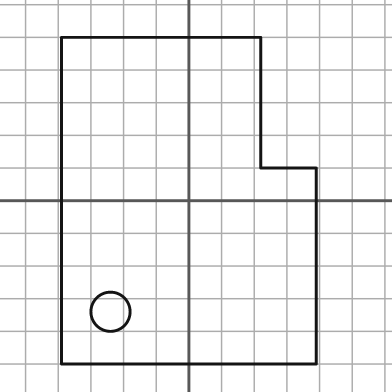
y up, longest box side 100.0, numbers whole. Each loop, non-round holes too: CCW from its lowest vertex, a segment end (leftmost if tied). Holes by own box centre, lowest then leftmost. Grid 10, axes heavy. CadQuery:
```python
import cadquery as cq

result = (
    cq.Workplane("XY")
    .moveTo(-39.0, -50.0)
    .lineTo(39.0, -50.0)
    .lineTo(39.0, 10.0)
    .lineTo(22.0, 10.0)
    .lineTo(22.0, 50.0)
    .lineTo(-39.0, 50.0)
    .close()
    .moveTo(-24.0, -34.0)
    .circle(6.0)
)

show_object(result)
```